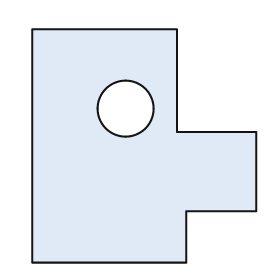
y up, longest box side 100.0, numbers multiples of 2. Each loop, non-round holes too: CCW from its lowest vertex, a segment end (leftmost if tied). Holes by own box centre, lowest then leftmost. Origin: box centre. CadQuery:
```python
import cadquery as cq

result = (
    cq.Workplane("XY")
    .moveTo(-48.0, -50.0)
    .lineTo(18.0, -50.0)
    .lineTo(18.0, -28.0)
    .lineTo(48.0, -28.0)
    .lineTo(48.0, 6.0)
    .lineTo(14.0, 6.0)
    .lineTo(14.0, 50.0)
    .lineTo(-48.0, 50.0)
    .close()
    .moveTo(-8.0, 16.0)
    .circle(12.0)
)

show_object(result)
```